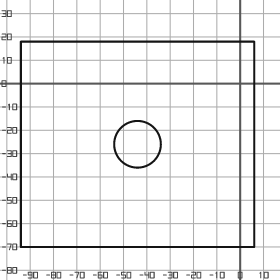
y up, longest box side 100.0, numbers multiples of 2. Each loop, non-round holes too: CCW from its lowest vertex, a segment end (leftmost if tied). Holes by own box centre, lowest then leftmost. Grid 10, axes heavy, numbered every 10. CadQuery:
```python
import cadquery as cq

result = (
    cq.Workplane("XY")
    .moveTo(-94.0, -70.0)
    .lineTo(6.0, -70.0)
    .lineTo(6.0, 18.0)
    .lineTo(-94.0, 18.0)
    .close()
    .moveTo(-44.0, -26.0)
    .circle(10.0)
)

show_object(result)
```